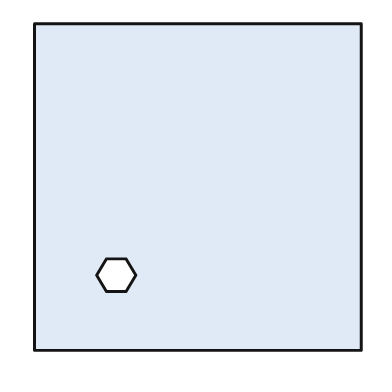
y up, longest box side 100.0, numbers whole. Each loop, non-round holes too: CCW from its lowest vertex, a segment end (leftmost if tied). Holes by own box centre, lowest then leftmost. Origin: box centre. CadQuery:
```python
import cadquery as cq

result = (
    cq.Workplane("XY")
    .moveTo(-50.0, -50.0)
    .lineTo(50.0, -50.0)
    .lineTo(50.0, 50.0)
    .lineTo(-50.0, 50.0)
    .close()
    .moveTo(-28.0, -32.0)
    .lineTo(-22.0, -32.0)
    .lineTo(-19.0, -27.0)
    .lineTo(-22.0, -22.0)
    .lineTo(-28.0, -22.0)
    .lineTo(-31.0, -27.0)
    .close()
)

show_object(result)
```